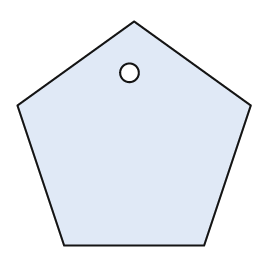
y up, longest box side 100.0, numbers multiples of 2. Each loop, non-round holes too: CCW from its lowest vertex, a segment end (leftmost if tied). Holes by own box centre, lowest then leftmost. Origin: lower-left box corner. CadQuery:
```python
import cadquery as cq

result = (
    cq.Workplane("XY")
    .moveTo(20.0, 0.0)
    .lineTo(80.0, 0.0)
    .lineTo(100.0, 60.0)
    .lineTo(50.0, 96.0)
    .lineTo(0.0, 60.0)
    .close()
    .moveTo(48.0, 74.0)
    .circle(4.0)
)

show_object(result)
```